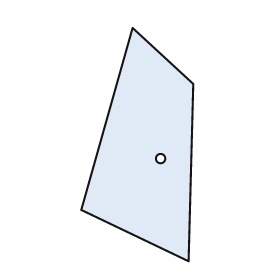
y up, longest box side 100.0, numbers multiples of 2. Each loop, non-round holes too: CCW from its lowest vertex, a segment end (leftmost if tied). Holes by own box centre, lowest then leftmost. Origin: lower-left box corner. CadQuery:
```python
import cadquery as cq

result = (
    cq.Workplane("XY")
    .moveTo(46.0, 0.0)
    .lineTo(48.0, 76.0)
    .lineTo(22.0, 100.0)
    .lineTo(0.0, 22.0)
    .close()
    .moveTo(34.0, 44.0)
    .circle(2.0)
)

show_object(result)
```